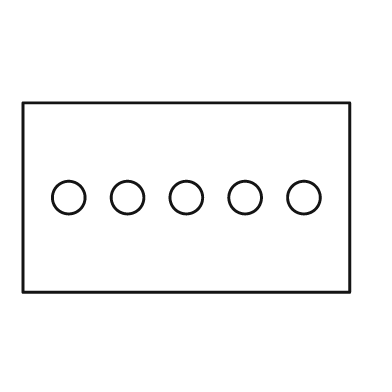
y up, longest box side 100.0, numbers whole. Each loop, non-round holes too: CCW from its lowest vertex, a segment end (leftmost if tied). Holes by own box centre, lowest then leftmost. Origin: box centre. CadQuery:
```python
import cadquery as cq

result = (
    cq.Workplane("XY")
    .moveTo(-50.0, -29.0)
    .lineTo(50.0, -29.0)
    .lineTo(50.0, 29.0)
    .lineTo(-50.0, 29.0)
    .close()
    .moveTo(-36.0, 0.0)
    .circle(5.0)
    .moveTo(-18.0, 0.0)
    .circle(5.0)
    .moveTo(0.0, 0.0)
    .circle(5.0)
    .moveTo(18.0, 0.0)
    .circle(5.0)
    .moveTo(36.0, 0.0)
    .circle(5.0)
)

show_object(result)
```